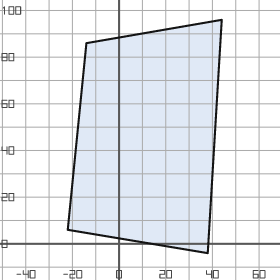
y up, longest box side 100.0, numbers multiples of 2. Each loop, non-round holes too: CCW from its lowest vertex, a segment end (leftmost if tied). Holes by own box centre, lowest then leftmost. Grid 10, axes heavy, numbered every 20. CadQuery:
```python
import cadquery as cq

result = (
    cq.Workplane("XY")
    .moveTo(38.0, -4.0)
    .lineTo(44.0, 96.0)
    .lineTo(-14.0, 86.0)
    .lineTo(-22.0, 6.0)
    .close()
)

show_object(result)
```